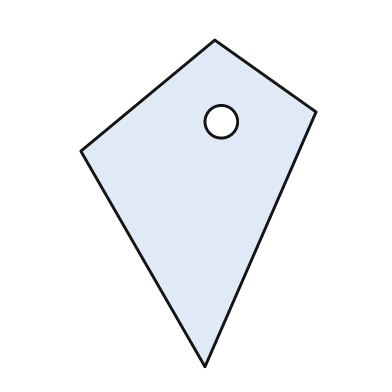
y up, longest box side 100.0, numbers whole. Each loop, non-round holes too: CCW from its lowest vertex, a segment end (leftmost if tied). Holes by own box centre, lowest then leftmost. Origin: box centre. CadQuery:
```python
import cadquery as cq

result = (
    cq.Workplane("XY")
    .moveTo(2.0, -50.0)
    .lineTo(36.0, 28.0)
    .lineTo(5.0, 50.0)
    .lineTo(-36.0, 16.0)
    .close()
    .moveTo(7.0, 25.0)
    .circle(5.0)
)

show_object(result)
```